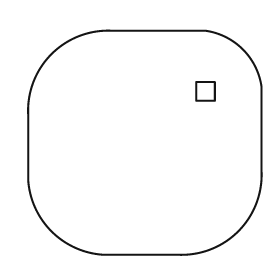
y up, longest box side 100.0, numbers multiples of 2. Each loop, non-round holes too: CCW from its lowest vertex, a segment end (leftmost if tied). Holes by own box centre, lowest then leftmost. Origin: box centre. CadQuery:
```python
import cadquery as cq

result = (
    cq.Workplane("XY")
    .moveTo(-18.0, -48.0)
    .lineTo(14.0, -48.0)
    .threePointArc((40.0, -38.0), (50.0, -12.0))
    .lineTo(50.0, 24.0)
    .threePointArc((42.0, 40.0), (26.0, 48.0))
    .lineTo(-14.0, 48.0)
    .threePointArc((-40.0, 38.0), (-50.0, 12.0))
    .lineTo(-50.0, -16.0)
    .threePointArc((-40.0, -38.0), (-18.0, -48.0))
    .close()
    .moveTo(22.0, 18.0)
    .lineTo(30.0, 18.0)
    .lineTo(30.0, 26.0)
    .lineTo(22.0, 26.0)
    .close()
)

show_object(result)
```